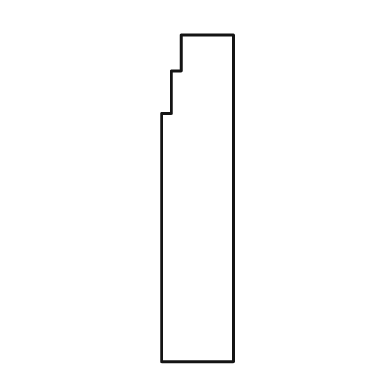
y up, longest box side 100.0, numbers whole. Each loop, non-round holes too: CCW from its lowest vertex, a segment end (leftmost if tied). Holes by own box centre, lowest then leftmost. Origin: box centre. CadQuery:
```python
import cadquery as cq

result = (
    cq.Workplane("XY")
    .moveTo(-11.0, -50.0)
    .lineTo(11.0, -50.0)
    .lineTo(11.0, 50.0)
    .lineTo(-5.0, 50.0)
    .lineTo(-5.0, 39.0)
    .lineTo(-8.0, 39.0)
    .lineTo(-8.0, 26.0)
    .lineTo(-11.0, 26.0)
    .close()
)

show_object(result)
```